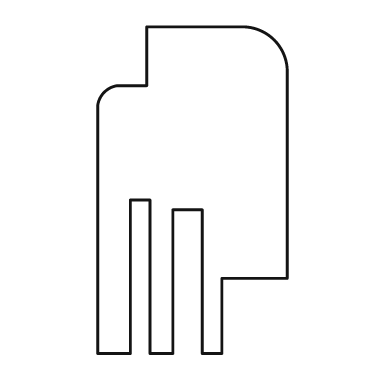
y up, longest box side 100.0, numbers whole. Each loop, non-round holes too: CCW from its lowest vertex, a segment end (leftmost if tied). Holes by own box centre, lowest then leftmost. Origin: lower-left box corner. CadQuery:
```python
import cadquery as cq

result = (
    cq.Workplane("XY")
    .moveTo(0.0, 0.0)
    .lineTo(10.0, 0.0)
    .lineTo(10.0, 47.0)
    .lineTo(16.0, 47.0)
    .lineTo(16.0, 0.0)
    .lineTo(23.0, 0.0)
    .lineTo(23.0, 44.0)
    .lineTo(32.0, 44.0)
    .lineTo(32.0, 0.0)
    .lineTo(38.0, 0.0)
    .lineTo(38.0, 23.0)
    .lineTo(58.0, 23.0)
    .lineTo(58.0, 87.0)
    .threePointArc((54.0, 96.0), (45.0, 100.0))
    .lineTo(15.0, 100.0)
    .lineTo(15.0, 82.0)
    .lineTo(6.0, 82.0)
    .threePointArc((2.0, 80.0), (0.0, 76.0))
    .close()
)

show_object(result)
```